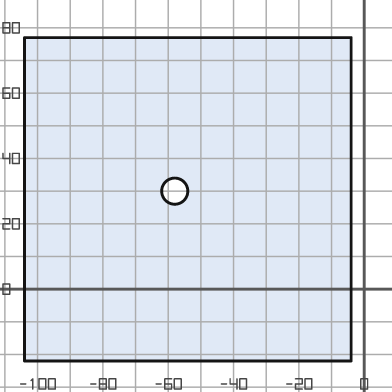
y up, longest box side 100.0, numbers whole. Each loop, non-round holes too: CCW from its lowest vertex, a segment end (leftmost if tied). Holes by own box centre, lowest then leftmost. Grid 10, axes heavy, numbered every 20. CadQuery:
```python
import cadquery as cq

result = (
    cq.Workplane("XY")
    .moveTo(-104.0, -22.0)
    .lineTo(-4.0, -22.0)
    .lineTo(-4.0, 77.0)
    .lineTo(-104.0, 77.0)
    .close()
    .moveTo(-58.0, 30.0)
    .circle(4.0)
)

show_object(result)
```